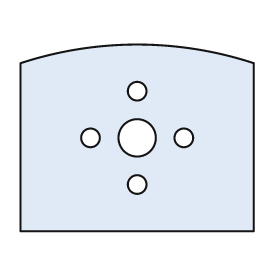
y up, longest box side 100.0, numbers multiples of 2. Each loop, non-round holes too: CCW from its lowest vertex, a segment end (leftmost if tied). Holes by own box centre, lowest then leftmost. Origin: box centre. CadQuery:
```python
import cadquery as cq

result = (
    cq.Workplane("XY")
    .moveTo(-50.0, -40.0)
    .lineTo(50.0, -40.0)
    .lineTo(50.0, 32.0)
    .threePointArc((0.0, 40.0), (-50.0, 32.0))
    .close()
    .moveTo(0.0, -20.0)
    .circle(4.0)
    .moveTo(-20.0, 0.0)
    .circle(4.0)
    .moveTo(0.0, 0.0)
    .circle(8.0)
    .moveTo(20.0, 0.0)
    .circle(4.0)
    .moveTo(0.0, 20.0)
    .circle(4.0)
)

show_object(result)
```